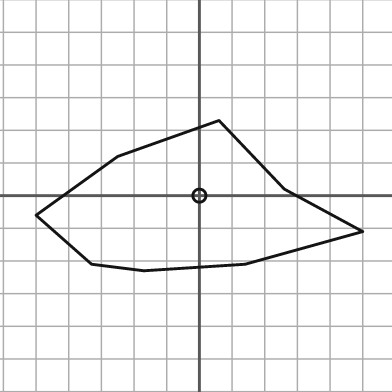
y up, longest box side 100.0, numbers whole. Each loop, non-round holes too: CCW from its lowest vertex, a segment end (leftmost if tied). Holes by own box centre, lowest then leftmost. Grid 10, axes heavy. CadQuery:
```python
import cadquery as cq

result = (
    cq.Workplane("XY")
    .moveTo(-17.0, -23.0)
    .lineTo(14.0, -21.0)
    .lineTo(50.0, -11.0)
    .lineTo(26.0, 2.0)
    .lineTo(6.0, 23.0)
    .lineTo(-25.0, 12.0)
    .lineTo(-50.0, -6.0)
    .lineTo(-33.0, -21.0)
    .close()
    .moveTo(0.0, 0.0)
    .circle(2.0)
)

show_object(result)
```